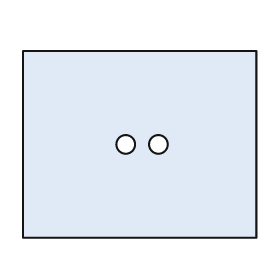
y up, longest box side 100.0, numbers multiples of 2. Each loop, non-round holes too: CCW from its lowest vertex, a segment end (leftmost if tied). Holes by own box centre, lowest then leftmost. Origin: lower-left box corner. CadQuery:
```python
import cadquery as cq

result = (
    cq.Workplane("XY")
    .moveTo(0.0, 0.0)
    .lineTo(100.0, 0.0)
    .lineTo(100.0, 80.0)
    .lineTo(0.0, 80.0)
    .close()
    .moveTo(44.0, 40.0)
    .circle(4.0)
    .moveTo(58.0, 40.0)
    .circle(4.0)
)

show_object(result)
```